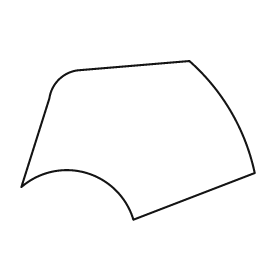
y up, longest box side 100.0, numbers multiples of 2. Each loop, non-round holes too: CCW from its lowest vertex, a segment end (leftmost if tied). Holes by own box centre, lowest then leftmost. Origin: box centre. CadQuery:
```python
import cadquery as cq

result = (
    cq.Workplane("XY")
    .moveTo(-2.0, -34.0)
    .lineTo(50.0, -14.0)
    .threePointArc((40.0, 12.0), (22.0, 34.0))
    .lineTo(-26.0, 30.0)
    .threePointArc((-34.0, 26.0), (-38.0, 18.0))
    .lineTo(-50.0, -20.0)
    .threePointArc((-22.0, -14.0), (-2.0, -34.0))
    .close()
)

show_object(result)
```